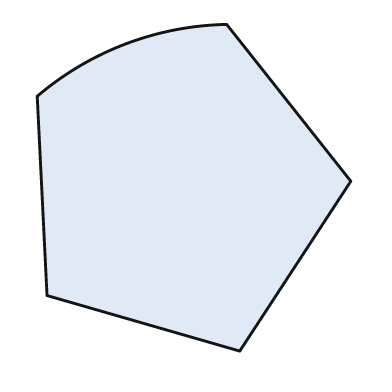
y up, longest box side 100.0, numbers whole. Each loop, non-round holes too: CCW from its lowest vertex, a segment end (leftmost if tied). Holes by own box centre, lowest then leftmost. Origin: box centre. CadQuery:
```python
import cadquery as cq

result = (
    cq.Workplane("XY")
    .moveTo(14.0, -50.0)
    .lineTo(48.0, 2.0)
    .lineTo(10.0, 50.0)
    .threePointArc((-21.0, 44.0), (-48.0, 28.0))
    .lineTo(-45.0, -33.0)
    .close()
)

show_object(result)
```